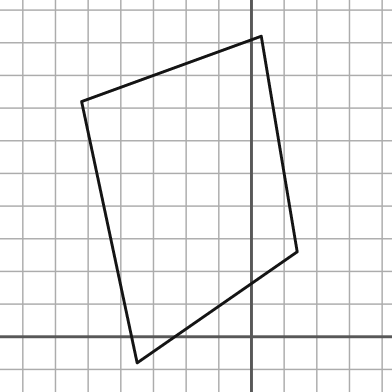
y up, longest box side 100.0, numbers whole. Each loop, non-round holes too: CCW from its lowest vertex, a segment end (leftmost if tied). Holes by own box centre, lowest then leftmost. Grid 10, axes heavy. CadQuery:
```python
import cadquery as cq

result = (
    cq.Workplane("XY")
    .moveTo(-35.0, -8.0)
    .lineTo(14.0, 26.0)
    .lineTo(3.0, 92.0)
    .lineTo(-52.0, 72.0)
    .close()
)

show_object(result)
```